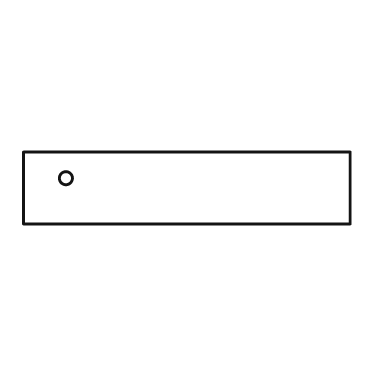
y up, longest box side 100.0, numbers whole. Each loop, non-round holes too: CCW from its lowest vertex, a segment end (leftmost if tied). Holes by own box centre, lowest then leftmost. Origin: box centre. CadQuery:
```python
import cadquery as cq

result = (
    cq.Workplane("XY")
    .moveTo(-50.0, -11.0)
    .lineTo(50.0, -11.0)
    .lineTo(50.0, 11.0)
    .lineTo(-50.0, 11.0)
    .close()
    .moveTo(-37.0, 3.0)
    .circle(2.0)
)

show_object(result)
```